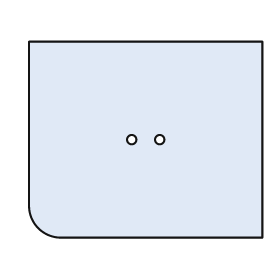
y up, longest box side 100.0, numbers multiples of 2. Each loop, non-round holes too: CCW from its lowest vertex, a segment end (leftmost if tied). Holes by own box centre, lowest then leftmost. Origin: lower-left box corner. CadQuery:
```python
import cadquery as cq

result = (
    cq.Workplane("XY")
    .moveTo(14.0, 0.0)
    .lineTo(100.0, 0.0)
    .lineTo(100.0, 84.0)
    .lineTo(0.0, 84.0)
    .lineTo(0.0, 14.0)
    .threePointArc((4.0, 4.0), (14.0, 0.0))
    .close()
    .moveTo(44.0, 42.0)
    .circle(2.0)
    .moveTo(56.0, 42.0)
    .circle(2.0)
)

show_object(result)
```